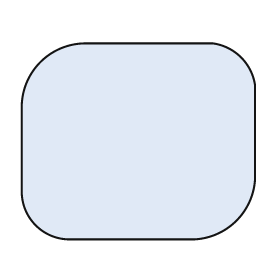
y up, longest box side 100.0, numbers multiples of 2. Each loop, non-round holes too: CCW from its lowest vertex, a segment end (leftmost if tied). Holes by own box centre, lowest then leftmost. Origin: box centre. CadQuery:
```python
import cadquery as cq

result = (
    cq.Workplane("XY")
    .moveTo(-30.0, -42.0)
    .lineTo(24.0, -42.0)
    .threePointArc((42.0, -34.0), (50.0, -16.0))
    .lineTo(50.0, 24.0)
    .threePointArc((44.0, 36.0), (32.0, 42.0))
    .lineTo(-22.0, 42.0)
    .threePointArc((-42.0, 34.0), (-50.0, 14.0))
    .lineTo(-50.0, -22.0)
    .threePointArc((-44.0, -36.0), (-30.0, -42.0))
    .close()
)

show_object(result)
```